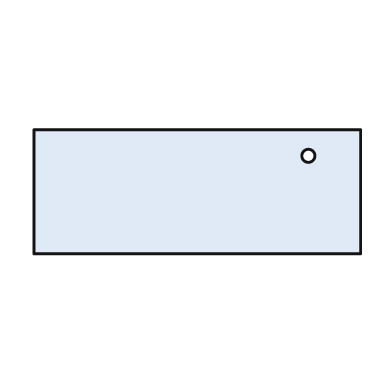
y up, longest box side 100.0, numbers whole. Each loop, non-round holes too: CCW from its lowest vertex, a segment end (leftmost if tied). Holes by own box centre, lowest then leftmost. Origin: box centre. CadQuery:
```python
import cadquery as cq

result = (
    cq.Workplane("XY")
    .moveTo(-50.0, -19.0)
    .lineTo(50.0, -19.0)
    .lineTo(50.0, 19.0)
    .lineTo(-50.0, 19.0)
    .close()
    .moveTo(34.0, 11.0)
    .circle(2.0)
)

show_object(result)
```